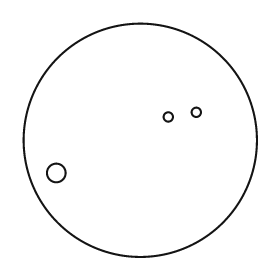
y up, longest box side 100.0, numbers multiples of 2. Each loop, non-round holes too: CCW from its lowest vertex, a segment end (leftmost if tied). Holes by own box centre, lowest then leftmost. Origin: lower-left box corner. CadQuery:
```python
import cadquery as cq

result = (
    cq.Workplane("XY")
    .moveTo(50.0, 50.0)
    .circle(50.0)
    .moveTo(14.0, 36.0)
    .circle(4.0)
    .moveTo(62.0, 60.0)
    .circle(2.0)
    .moveTo(74.0, 62.0)
    .circle(2.0)
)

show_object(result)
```